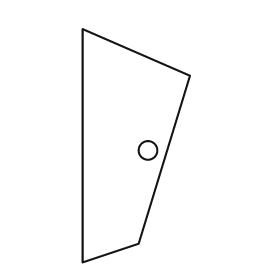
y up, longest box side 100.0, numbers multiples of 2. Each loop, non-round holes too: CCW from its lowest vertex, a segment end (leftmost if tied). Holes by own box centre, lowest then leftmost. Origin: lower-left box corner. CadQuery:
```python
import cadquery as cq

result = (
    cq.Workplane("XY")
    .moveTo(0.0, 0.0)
    .lineTo(24.0, 8.0)
    .lineTo(46.0, 80.0)
    .lineTo(0.0, 100.0)
    .close()
    .moveTo(28.0, 48.0)
    .circle(4.0)
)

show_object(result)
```